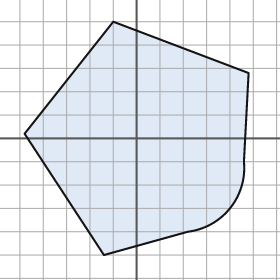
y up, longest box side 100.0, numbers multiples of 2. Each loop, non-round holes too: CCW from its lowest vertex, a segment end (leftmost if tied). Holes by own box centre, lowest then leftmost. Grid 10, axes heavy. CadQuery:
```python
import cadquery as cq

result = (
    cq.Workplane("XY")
    .moveTo(-14.0, -50.0)
    .lineTo(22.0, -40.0)
    .threePointArc((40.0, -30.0), (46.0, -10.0))
    .lineTo(48.0, 28.0)
    .lineTo(-10.0, 50.0)
    .lineTo(-48.0, 2.0)
    .close()
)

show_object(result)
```